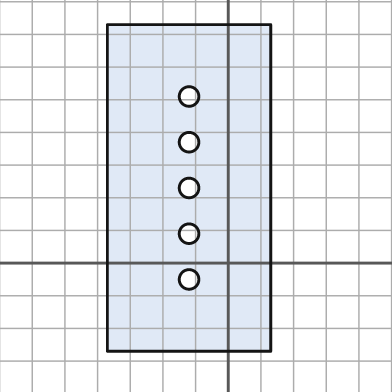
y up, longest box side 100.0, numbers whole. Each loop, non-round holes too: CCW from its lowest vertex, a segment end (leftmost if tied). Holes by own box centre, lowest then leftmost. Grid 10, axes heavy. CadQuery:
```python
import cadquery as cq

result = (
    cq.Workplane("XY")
    .moveTo(-37.0, -27.0)
    .lineTo(13.0, -27.0)
    .lineTo(13.0, 73.0)
    .lineTo(-37.0, 73.0)
    .close()
    .moveTo(-12.0, -5.0)
    .circle(3.0)
    .moveTo(-12.0, 9.0)
    .circle(3.0)
    .moveTo(-12.0, 23.0)
    .circle(3.0)
    .moveTo(-12.0, 37.0)
    .circle(3.0)
    .moveTo(-12.0, 51.0)
    .circle(3.0)
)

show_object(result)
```